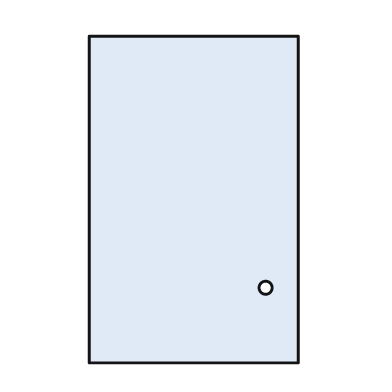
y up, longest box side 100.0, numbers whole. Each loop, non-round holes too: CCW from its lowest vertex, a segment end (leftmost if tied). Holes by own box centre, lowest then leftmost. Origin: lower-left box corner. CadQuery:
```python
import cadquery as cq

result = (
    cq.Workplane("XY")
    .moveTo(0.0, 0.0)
    .lineTo(64.0, 0.0)
    .lineTo(64.0, 100.0)
    .lineTo(0.0, 100.0)
    .close()
    .moveTo(54.0, 23.0)
    .circle(2.0)
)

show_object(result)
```